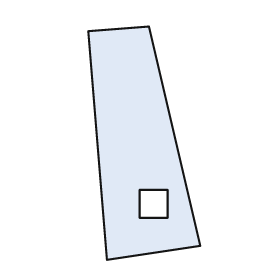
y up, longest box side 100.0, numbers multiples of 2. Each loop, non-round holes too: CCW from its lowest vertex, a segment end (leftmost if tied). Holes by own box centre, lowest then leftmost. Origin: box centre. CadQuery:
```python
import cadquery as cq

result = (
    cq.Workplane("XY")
    .moveTo(-16.0, -50.0)
    .lineTo(24.0, -44.0)
    .lineTo(2.0, 50.0)
    .lineTo(-24.0, 48.0)
    .close()
    .moveTo(-2.0, -32.0)
    .lineTo(10.0, -32.0)
    .lineTo(10.0, -20.0)
    .lineTo(-2.0, -20.0)
    .close()
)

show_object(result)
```